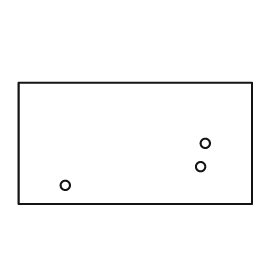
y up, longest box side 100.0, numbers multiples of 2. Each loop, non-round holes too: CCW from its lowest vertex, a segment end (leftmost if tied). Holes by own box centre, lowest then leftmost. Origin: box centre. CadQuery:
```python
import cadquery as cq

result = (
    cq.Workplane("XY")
    .moveTo(-50.0, -26.0)
    .lineTo(50.0, -26.0)
    .lineTo(50.0, 26.0)
    .lineTo(-50.0, 26.0)
    .close()
    .moveTo(-30.0, -18.0)
    .circle(2.0)
    .moveTo(28.0, -10.0)
    .circle(2.0)
    .moveTo(30.0, 0.0)
    .circle(2.0)
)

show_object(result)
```